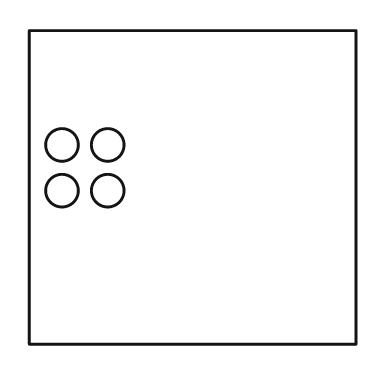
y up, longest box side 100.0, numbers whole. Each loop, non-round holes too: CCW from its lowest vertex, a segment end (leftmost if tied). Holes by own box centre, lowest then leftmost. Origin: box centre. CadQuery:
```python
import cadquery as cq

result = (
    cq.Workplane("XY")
    .moveTo(-50.0, -48.0)
    .lineTo(50.0, -48.0)
    .lineTo(50.0, 48.0)
    .lineTo(-50.0, 48.0)
    .close()
    .moveTo(-40.0, -1.0)
    .circle(5.0)
    .moveTo(-26.0, -1.0)
    .circle(5.0)
    .moveTo(-40.0, 13.0)
    .circle(5.0)
    .moveTo(-26.0, 13.0)
    .circle(5.0)
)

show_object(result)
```